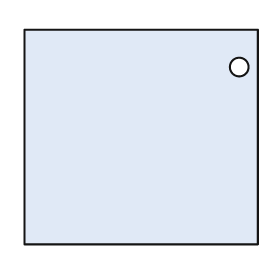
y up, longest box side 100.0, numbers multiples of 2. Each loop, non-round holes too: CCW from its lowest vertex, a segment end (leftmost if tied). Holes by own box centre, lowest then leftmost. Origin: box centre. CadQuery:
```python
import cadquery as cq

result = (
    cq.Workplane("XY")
    .moveTo(-50.0, -46.0)
    .lineTo(50.0, -46.0)
    .lineTo(50.0, 46.0)
    .lineTo(-50.0, 46.0)
    .close()
    .moveTo(42.0, 30.0)
    .circle(4.0)
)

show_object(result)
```